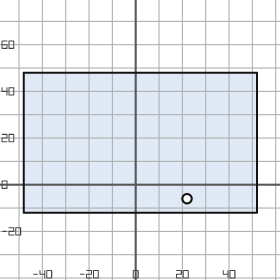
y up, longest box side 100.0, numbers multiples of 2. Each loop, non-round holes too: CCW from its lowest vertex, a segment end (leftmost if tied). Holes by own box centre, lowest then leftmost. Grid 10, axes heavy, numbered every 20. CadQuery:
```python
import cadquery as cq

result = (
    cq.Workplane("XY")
    .moveTo(-48.0, -12.0)
    .lineTo(52.0, -12.0)
    .lineTo(52.0, 48.0)
    .lineTo(-48.0, 48.0)
    .close()
    .moveTo(22.0, -6.0)
    .circle(2.0)
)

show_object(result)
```